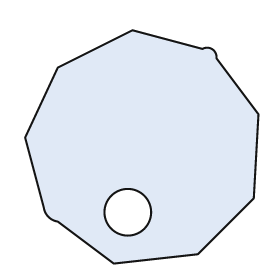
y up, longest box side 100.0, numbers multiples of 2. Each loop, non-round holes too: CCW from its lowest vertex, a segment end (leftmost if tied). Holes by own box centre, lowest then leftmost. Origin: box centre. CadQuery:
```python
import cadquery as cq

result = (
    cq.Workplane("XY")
    .moveTo(-12.0, -50.0)
    .lineTo(24.0, -46.0)
    .lineTo(48.0, -22.0)
    .lineTo(50.0, 14.0)
    .lineTo(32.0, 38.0)
    .threePointArc((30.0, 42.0), (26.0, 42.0))
    .lineTo(-4.0, 50.0)
    .lineTo(-36.0, 34.0)
    .lineTo(-50.0, 4.0)
    .lineTo(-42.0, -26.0)
    .threePointArc((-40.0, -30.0), (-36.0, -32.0))
    .close()
    .moveTo(-6.0, -28.0)
    .circle(10.0)
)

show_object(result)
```